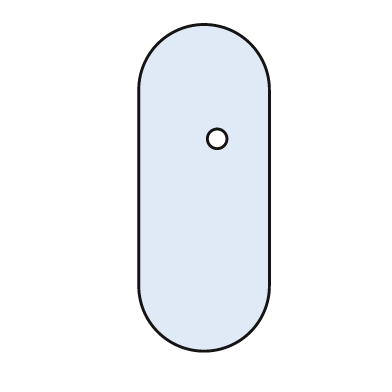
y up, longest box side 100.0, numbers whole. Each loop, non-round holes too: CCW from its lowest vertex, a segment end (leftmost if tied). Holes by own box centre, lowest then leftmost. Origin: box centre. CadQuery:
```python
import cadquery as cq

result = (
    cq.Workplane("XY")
    .moveTo(-20.0, -30.0)
    .threePointArc((0.0, -50.0), (20.0, -30.0))
    .lineTo(20.0, 30.0)
    .threePointArc((0.0, 50.0), (-20.0, 30.0))
    .close()
    .moveTo(4.0, 15.0)
    .circle(3.0)
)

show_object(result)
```